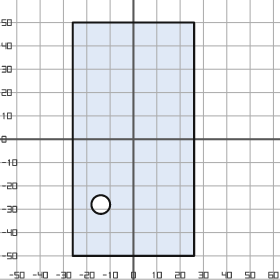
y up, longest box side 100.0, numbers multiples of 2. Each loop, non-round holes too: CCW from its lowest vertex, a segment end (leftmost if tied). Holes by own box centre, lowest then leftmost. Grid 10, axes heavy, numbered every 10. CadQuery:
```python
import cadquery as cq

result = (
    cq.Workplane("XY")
    .moveTo(-26.0, -50.0)
    .lineTo(26.0, -50.0)
    .lineTo(26.0, 50.0)
    .lineTo(-26.0, 50.0)
    .close()
    .moveTo(-14.0, -28.0)
    .circle(4.0)
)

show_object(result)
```